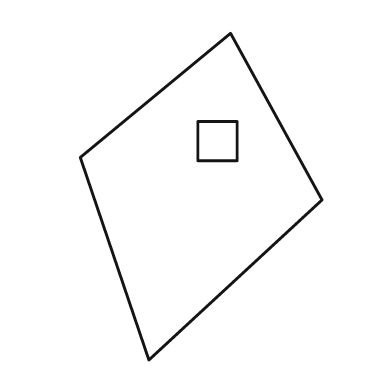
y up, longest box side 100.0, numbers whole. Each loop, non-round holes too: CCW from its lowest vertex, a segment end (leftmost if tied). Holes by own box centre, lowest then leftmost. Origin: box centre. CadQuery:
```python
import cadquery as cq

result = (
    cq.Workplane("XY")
    .moveTo(-16.0, -50.0)
    .lineTo(37.0, -1.0)
    .lineTo(9.0, 50.0)
    .lineTo(-37.0, 12.0)
    .close()
    .moveTo(-1.0, 11.0)
    .lineTo(11.0, 11.0)
    .lineTo(11.0, 23.0)
    .lineTo(-1.0, 23.0)
    .close()
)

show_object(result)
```